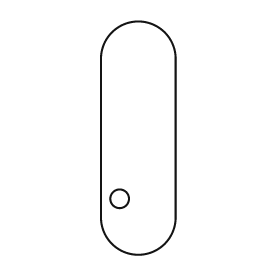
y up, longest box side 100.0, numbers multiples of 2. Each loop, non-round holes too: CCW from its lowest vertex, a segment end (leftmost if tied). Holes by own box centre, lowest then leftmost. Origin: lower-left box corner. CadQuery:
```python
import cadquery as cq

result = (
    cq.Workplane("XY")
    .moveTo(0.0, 16.0)
    .threePointArc((16.0, 0.0), (32.0, 16.0))
    .lineTo(32.0, 84.0)
    .threePointArc((16.0, 100.0), (0.0, 84.0))
    .close()
    .moveTo(8.0, 24.0)
    .circle(4.0)
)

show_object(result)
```